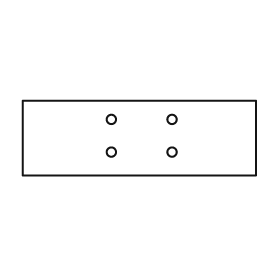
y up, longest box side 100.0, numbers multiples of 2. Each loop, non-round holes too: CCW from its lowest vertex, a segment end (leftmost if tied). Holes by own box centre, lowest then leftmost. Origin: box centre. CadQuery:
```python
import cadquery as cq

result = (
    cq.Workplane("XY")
    .moveTo(-50.0, -16.0)
    .lineTo(50.0, -16.0)
    .lineTo(50.0, 16.0)
    .lineTo(-50.0, 16.0)
    .close()
    .moveTo(-12.0, -6.0)
    .circle(2.0)
    .moveTo(14.0, -6.0)
    .circle(2.0)
    .moveTo(-12.0, 8.0)
    .circle(2.0)
    .moveTo(14.0, 8.0)
    .circle(2.0)
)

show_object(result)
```